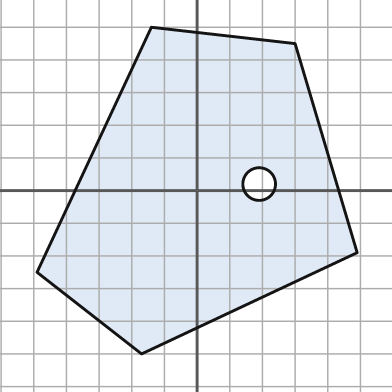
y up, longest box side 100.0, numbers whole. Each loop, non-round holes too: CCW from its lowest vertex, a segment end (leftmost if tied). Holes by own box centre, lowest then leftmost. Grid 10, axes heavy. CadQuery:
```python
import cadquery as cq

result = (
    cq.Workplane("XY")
    .moveTo(-17.0, -50.0)
    .lineTo(49.0, -19.0)
    .lineTo(30.0, 45.0)
    .lineTo(-14.0, 50.0)
    .lineTo(-49.0, -25.0)
    .close()
    .moveTo(19.0, 2.0)
    .circle(5.0)
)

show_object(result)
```